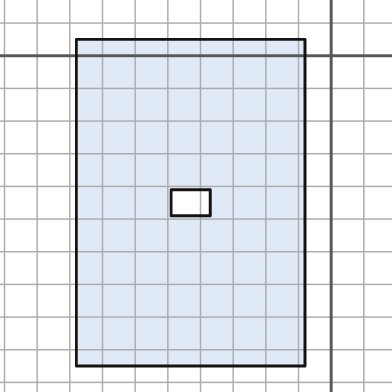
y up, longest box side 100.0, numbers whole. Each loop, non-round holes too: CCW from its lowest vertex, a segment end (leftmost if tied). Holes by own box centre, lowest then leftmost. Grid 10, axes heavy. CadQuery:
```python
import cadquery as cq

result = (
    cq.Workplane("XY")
    .moveTo(-78.0, -95.0)
    .lineTo(-8.0, -95.0)
    .lineTo(-8.0, 5.0)
    .lineTo(-78.0, 5.0)
    .close()
    .moveTo(-49.0, -49.0)
    .lineTo(-37.0, -49.0)
    .lineTo(-37.0, -41.0)
    .lineTo(-49.0, -41.0)
    .close()
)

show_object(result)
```